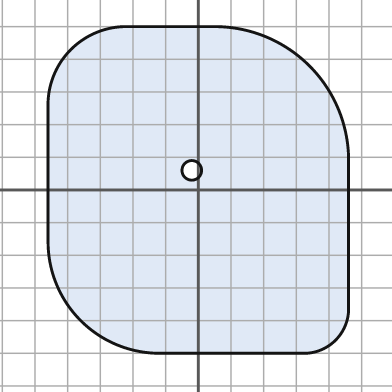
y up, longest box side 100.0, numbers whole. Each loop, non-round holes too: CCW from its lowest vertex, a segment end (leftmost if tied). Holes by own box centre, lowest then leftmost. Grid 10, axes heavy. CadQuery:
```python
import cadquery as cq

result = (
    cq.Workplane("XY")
    .moveTo(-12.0, -50.0)
    .lineTo(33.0, -50.0)
    .threePointArc((42.0, -46.0), (46.0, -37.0))
    .lineTo(46.0, 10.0)
    .threePointArc((34.0, 38.0), (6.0, 50.0))
    .lineTo(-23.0, 50.0)
    .threePointArc((-39.0, 43.0), (-46.0, 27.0))
    .lineTo(-46.0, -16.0)
    .threePointArc((-36.0, -40.0), (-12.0, -50.0))
    .close()
    .moveTo(-2.0, 6.0)
    .circle(3.0)
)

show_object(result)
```